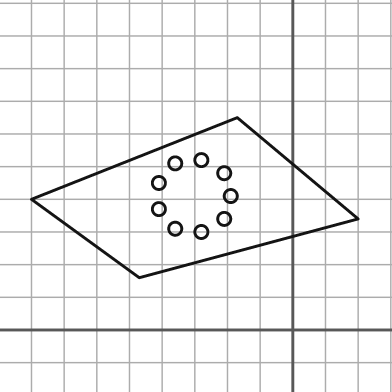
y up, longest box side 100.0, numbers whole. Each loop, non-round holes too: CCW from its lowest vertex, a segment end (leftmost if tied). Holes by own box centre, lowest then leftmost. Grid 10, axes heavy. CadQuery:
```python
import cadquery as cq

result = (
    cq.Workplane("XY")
    .moveTo(-47.0, 16.0)
    .lineTo(20.0, 34.0)
    .lineTo(-17.0, 65.0)
    .lineTo(-80.0, 40.0)
    .close()
    .moveTo(-28.0, 30.0)
    .circle(2.0)
    .moveTo(-36.0, 31.0)
    .circle(2.0)
    .moveTo(-21.0, 34.0)
    .circle(2.0)
    .moveTo(-41.0, 37.0)
    .circle(2.0)
    .moveTo(-19.0, 41.0)
    .circle(2.0)
    .moveTo(-41.0, 45.0)
    .circle(2.0)
    .moveTo(-21.0, 48.0)
    .circle(2.0)
    .moveTo(-36.0, 51.0)
    .circle(2.0)
    .moveTo(-28.0, 52.0)
    .circle(2.0)
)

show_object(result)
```